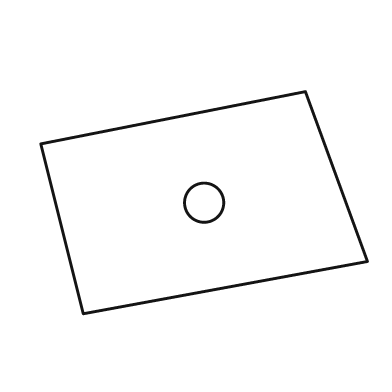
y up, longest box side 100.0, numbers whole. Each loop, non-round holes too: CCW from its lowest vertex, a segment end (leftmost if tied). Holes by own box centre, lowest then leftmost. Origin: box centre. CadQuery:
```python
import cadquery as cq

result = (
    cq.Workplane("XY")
    .moveTo(-37.0, -34.0)
    .lineTo(50.0, -18.0)
    .lineTo(31.0, 34.0)
    .lineTo(-50.0, 18.0)
    .close()
    .moveTo(0.0, 0.0)
    .circle(6.0)
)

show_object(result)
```